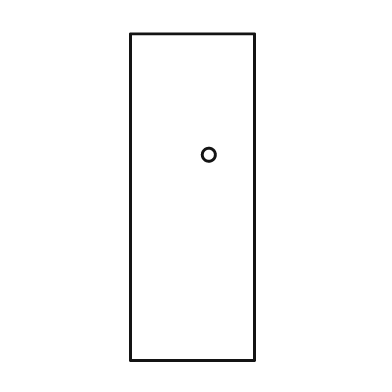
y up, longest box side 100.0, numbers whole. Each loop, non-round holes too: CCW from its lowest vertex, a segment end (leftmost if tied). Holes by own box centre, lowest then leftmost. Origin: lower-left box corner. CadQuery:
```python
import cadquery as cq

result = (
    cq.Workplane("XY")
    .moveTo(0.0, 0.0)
    .lineTo(38.0, 0.0)
    .lineTo(38.0, 100.0)
    .lineTo(0.0, 100.0)
    .close()
    .moveTo(24.0, 63.0)
    .circle(2.0)
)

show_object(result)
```